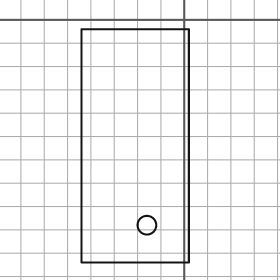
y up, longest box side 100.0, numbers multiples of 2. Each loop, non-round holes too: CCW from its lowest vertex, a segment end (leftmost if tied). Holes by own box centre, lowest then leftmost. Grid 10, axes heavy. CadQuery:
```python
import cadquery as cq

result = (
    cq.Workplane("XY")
    .moveTo(-44.0, -104.0)
    .lineTo(2.0, -104.0)
    .lineTo(2.0, -4.0)
    .lineTo(-44.0, -4.0)
    .close()
    .moveTo(-16.0, -88.0)
    .circle(4.0)
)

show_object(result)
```